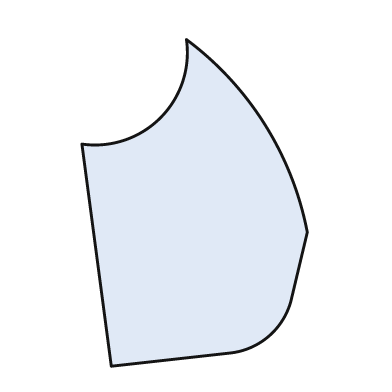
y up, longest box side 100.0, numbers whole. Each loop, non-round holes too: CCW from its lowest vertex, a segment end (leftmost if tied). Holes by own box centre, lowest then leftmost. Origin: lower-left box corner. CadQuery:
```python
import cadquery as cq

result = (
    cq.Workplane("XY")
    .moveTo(9.0, 0.0)
    .lineTo(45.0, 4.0)
    .threePointArc((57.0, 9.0), (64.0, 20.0))
    .lineTo(69.0, 41.0)
    .threePointArc((56.0, 74.0), (32.0, 100.0))
    .threePointArc((24.0, 76.0), (0.0, 68.0))
    .close()
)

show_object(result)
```